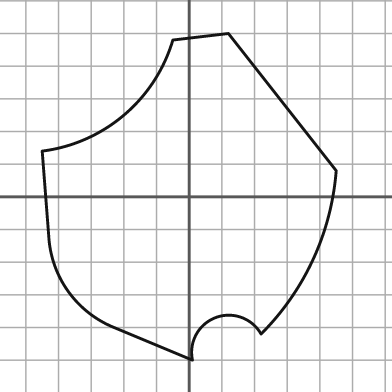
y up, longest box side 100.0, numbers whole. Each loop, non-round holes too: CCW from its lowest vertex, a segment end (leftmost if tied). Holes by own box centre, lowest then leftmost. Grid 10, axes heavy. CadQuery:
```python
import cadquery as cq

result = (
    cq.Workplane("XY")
    .moveTo(1.0, -50.0)
    .threePointArc((8.0, -37.0), (22.0, -42.0))
    .threePointArc((38.0, -19.0), (45.0, 8.0))
    .lineTo(12.0, 50.0)
    .lineTo(-5.0, 48.0)
    .threePointArc((-20.0, 25.0), (-45.0, 14.0))
    .lineTo(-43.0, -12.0)
    .threePointArc((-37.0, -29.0), (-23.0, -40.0))
    .close()
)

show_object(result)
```